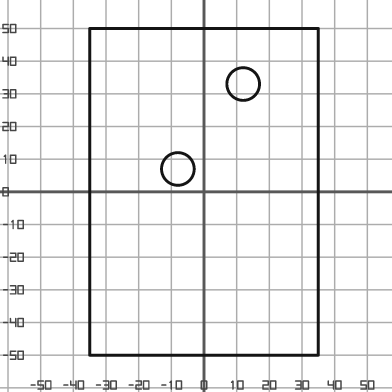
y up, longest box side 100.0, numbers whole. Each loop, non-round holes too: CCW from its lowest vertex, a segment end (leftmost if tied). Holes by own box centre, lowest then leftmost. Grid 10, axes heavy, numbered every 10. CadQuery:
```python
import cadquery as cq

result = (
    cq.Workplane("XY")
    .moveTo(-35.0, -50.0)
    .lineTo(35.0, -50.0)
    .lineTo(35.0, 50.0)
    .lineTo(-35.0, 50.0)
    .close()
    .moveTo(-8.0, 7.0)
    .circle(5.0)
    .moveTo(12.0, 33.0)
    .circle(5.0)
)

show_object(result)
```